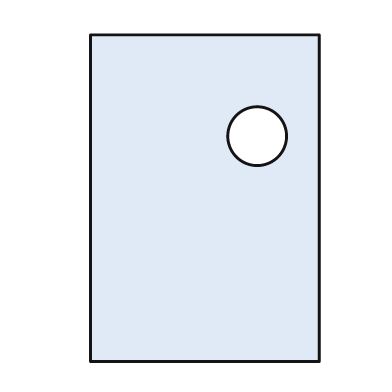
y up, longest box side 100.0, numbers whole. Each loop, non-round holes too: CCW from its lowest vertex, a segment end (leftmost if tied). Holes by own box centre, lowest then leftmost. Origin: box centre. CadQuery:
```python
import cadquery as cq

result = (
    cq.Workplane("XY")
    .moveTo(-35.0, -50.0)
    .lineTo(35.0, -50.0)
    .lineTo(35.0, 50.0)
    .lineTo(-35.0, 50.0)
    .close()
    .moveTo(16.0, 19.0)
    .circle(9.0)
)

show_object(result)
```